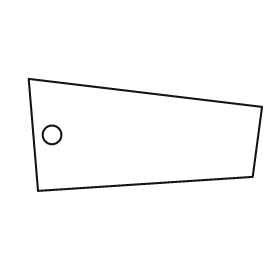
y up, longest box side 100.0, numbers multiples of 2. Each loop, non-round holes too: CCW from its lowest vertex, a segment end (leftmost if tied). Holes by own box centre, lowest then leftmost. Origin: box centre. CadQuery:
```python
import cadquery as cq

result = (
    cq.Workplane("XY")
    .moveTo(-46.0, -24.0)
    .lineTo(46.0, -18.0)
    .lineTo(50.0, 12.0)
    .lineTo(-50.0, 24.0)
    .close()
    .moveTo(-40.0, 0.0)
    .circle(4.0)
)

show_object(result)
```